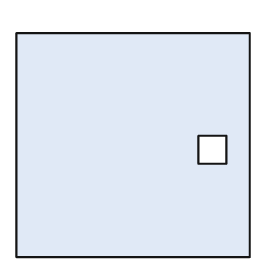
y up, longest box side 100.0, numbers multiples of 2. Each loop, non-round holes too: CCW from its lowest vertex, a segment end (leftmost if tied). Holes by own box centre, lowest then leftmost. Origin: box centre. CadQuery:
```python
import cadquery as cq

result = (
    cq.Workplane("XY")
    .moveTo(-50.0, -48.0)
    .lineTo(50.0, -48.0)
    .lineTo(50.0, 48.0)
    .lineTo(-50.0, 48.0)
    .close()
    .moveTo(28.0, -8.0)
    .lineTo(40.0, -8.0)
    .lineTo(40.0, 4.0)
    .lineTo(28.0, 4.0)
    .close()
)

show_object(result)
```